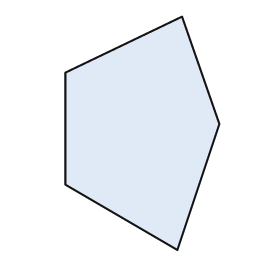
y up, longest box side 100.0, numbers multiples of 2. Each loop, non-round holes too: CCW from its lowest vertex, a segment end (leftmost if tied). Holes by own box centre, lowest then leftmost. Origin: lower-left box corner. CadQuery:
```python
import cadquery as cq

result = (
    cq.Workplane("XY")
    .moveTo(48.0, 0.0)
    .lineTo(66.0, 54.0)
    .lineTo(50.0, 100.0)
    .lineTo(0.0, 76.0)
    .lineTo(0.0, 28.0)
    .close()
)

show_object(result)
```